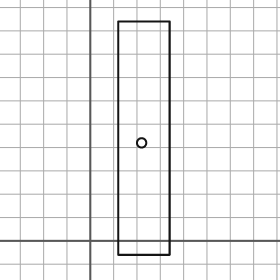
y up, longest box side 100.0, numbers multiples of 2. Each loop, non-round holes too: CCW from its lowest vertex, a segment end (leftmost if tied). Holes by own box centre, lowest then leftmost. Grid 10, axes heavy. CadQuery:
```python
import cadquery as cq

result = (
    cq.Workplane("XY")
    .moveTo(12.0, -6.0)
    .lineTo(34.0, -6.0)
    .lineTo(34.0, 94.0)
    .lineTo(12.0, 94.0)
    .close()
    .moveTo(22.0, 42.0)
    .circle(2.0)
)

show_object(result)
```